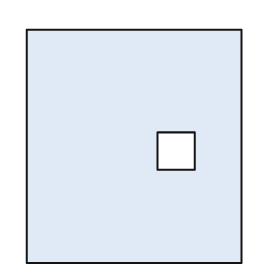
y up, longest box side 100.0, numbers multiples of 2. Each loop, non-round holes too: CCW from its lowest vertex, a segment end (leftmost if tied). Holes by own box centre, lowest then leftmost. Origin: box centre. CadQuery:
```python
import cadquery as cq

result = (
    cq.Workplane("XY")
    .moveTo(-46.0, -50.0)
    .lineTo(46.0, -50.0)
    .lineTo(46.0, 50.0)
    .lineTo(-46.0, 50.0)
    .close()
    .moveTo(10.0, -10.0)
    .lineTo(26.0, -10.0)
    .lineTo(26.0, 6.0)
    .lineTo(10.0, 6.0)
    .close()
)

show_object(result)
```